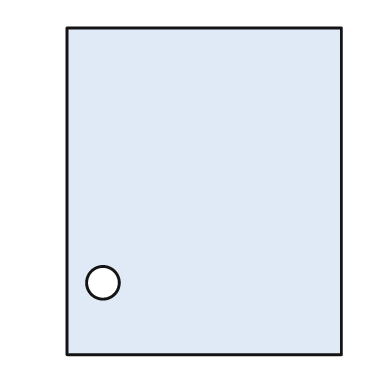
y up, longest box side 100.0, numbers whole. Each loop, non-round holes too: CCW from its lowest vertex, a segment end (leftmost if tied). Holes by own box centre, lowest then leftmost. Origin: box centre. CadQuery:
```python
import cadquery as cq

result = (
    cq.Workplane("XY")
    .moveTo(-42.0, -50.0)
    .lineTo(42.0, -50.0)
    .lineTo(42.0, 50.0)
    .lineTo(-42.0, 50.0)
    .close()
    .moveTo(-31.0, -28.0)
    .circle(5.0)
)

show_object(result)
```